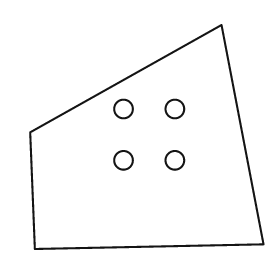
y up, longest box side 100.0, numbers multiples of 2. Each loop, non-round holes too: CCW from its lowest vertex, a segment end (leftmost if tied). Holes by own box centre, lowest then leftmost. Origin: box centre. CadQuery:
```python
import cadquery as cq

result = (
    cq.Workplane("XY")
    .moveTo(-48.0, -48.0)
    .lineTo(50.0, -46.0)
    .lineTo(32.0, 48.0)
    .lineTo(-50.0, 2.0)
    .close()
    .moveTo(-10.0, -10.0)
    .circle(4.0)
    .moveTo(12.0, -10.0)
    .circle(4.0)
    .moveTo(-10.0, 12.0)
    .circle(4.0)
    .moveTo(12.0, 12.0)
    .circle(4.0)
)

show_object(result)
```